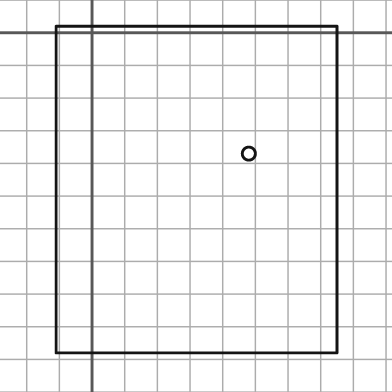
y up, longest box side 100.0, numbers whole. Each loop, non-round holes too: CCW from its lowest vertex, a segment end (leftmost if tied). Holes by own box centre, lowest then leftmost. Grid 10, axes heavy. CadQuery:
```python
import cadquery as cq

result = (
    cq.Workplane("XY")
    .moveTo(-11.0, -98.0)
    .lineTo(75.0, -98.0)
    .lineTo(75.0, 2.0)
    .lineTo(-11.0, 2.0)
    .close()
    .moveTo(48.0, -37.0)
    .circle(2.0)
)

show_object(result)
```